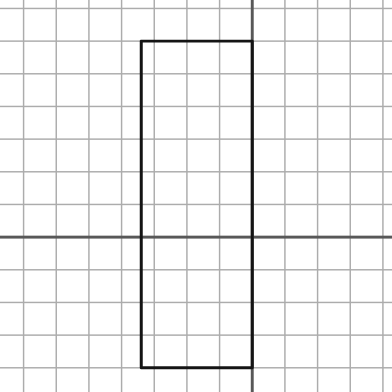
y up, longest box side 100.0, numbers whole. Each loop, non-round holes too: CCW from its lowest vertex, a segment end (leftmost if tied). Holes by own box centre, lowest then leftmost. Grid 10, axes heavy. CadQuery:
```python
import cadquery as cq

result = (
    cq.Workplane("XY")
    .moveTo(-34.0, -40.0)
    .lineTo(0.0, -40.0)
    .lineTo(0.0, 60.0)
    .lineTo(-34.0, 60.0)
    .close()
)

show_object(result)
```